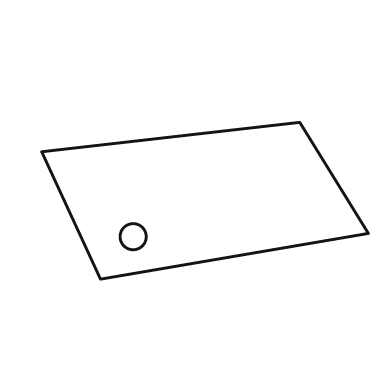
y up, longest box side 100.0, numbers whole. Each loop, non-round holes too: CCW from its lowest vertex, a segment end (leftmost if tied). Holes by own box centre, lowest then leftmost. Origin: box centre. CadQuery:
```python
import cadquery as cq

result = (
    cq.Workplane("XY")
    .moveTo(-32.0, -24.0)
    .lineTo(50.0, -10.0)
    .lineTo(29.0, 24.0)
    .lineTo(-50.0, 15.0)
    .close()
    .moveTo(-22.0, -11.0)
    .circle(4.0)
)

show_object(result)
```